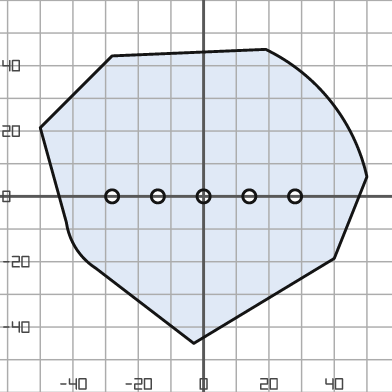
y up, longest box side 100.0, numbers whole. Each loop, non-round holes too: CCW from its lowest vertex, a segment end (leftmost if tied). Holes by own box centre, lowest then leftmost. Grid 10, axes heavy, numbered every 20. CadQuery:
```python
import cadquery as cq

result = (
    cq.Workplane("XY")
    .moveTo(-3.0, -45.0)
    .lineTo(40.0, -19.0)
    .lineTo(50.0, 6.0)
    .threePointArc((39.0, 29.0), (19.0, 45.0))
    .lineTo(-28.0, 43.0)
    .lineTo(-50.0, 21.0)
    .lineTo(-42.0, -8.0)
    .threePointArc((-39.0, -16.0), (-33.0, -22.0))
    .close()
    .moveTo(-28.0, 0.0)
    .circle(2.0)
    .moveTo(-14.0, 0.0)
    .circle(2.0)
    .moveTo(0.0, 0.0)
    .circle(2.0)
    .moveTo(14.0, 0.0)
    .circle(2.0)
    .moveTo(28.0, 0.0)
    .circle(2.0)
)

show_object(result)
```